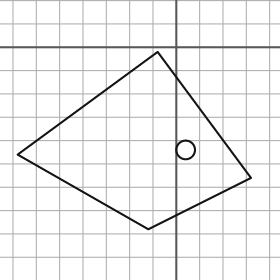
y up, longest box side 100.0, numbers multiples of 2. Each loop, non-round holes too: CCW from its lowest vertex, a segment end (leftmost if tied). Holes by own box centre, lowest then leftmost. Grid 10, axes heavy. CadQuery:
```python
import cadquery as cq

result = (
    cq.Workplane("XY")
    .moveTo(-12.0, -78.0)
    .lineTo(32.0, -56.0)
    .lineTo(-8.0, -2.0)
    .lineTo(-68.0, -46.0)
    .close()
    .moveTo(4.0, -44.0)
    .circle(4.0)
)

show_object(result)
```